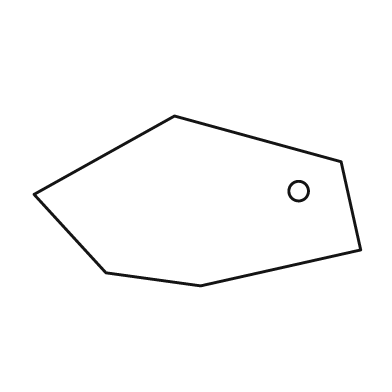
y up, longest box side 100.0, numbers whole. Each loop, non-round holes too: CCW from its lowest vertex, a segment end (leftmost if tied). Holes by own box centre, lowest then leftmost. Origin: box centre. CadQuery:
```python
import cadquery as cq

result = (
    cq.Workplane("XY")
    .moveTo(1.0, -26.0)
    .lineTo(50.0, -15.0)
    .lineTo(44.0, 12.0)
    .lineTo(-7.0, 26.0)
    .lineTo(-50.0, 2.0)
    .lineTo(-28.0, -22.0)
    .close()
    .moveTo(31.0, 3.0)
    .circle(3.0)
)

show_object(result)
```